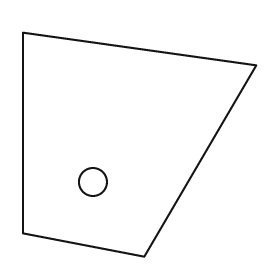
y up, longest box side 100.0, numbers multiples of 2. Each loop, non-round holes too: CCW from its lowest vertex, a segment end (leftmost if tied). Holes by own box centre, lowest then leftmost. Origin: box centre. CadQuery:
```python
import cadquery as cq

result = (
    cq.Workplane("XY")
    .moveTo(2.0, -48.0)
    .lineTo(50.0, 34.0)
    .lineTo(-50.0, 48.0)
    .lineTo(-50.0, -38.0)
    .close()
    .moveTo(-20.0, -16.0)
    .circle(6.0)
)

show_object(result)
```